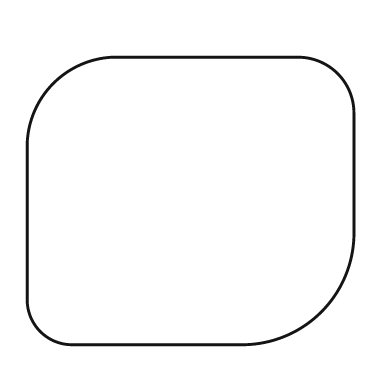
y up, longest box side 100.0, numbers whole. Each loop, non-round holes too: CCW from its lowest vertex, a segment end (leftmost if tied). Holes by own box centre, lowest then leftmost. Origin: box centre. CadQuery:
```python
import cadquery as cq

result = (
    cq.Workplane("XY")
    .moveTo(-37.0, -44.0)
    .lineTo(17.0, -44.0)
    .threePointArc((40.0, -34.0), (50.0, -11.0))
    .lineTo(50.0, 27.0)
    .threePointArc((45.0, 39.0), (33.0, 44.0))
    .lineTo(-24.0, 44.0)
    .threePointArc((-42.0, 36.0), (-50.0, 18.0))
    .lineTo(-50.0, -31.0)
    .threePointArc((-46.0, -40.0), (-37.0, -44.0))
    .close()
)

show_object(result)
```